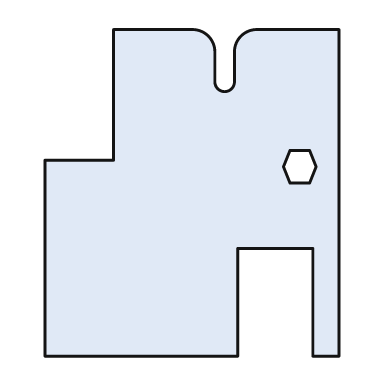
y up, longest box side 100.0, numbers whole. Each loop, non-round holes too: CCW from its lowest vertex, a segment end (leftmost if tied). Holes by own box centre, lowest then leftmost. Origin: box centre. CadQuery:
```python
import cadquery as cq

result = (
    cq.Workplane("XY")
    .moveTo(-45.0, -50.0)
    .lineTo(14.0, -50.0)
    .lineTo(14.0, -17.0)
    .lineTo(37.0, -17.0)
    .lineTo(37.0, -50.0)
    .lineTo(45.0, -50.0)
    .lineTo(45.0, 50.0)
    .lineTo(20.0, 50.0)
    .threePointArc((15.0, 48.0), (13.0, 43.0))
    .lineTo(13.0, 34.0)
    .threePointArc((10.0, 31.0), (7.0, 34.0))
    .lineTo(7.0, 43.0)
    .threePointArc((5.0, 48.0), (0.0, 50.0))
    .lineTo(-24.0, 50.0)
    .lineTo(-24.0, 10.0)
    .lineTo(-45.0, 10.0)
    .close()
    .moveTo(30.0, 3.0)
    .lineTo(36.0, 3.0)
    .lineTo(38.0, 8.0)
    .lineTo(36.0, 13.0)
    .lineTo(30.0, 13.0)
    .lineTo(28.0, 8.0)
    .close()
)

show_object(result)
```